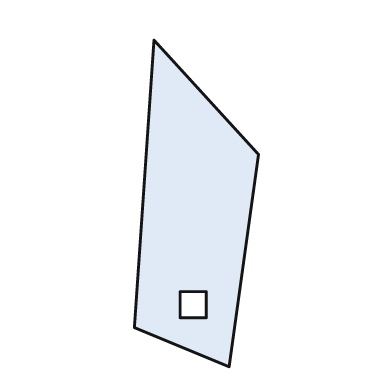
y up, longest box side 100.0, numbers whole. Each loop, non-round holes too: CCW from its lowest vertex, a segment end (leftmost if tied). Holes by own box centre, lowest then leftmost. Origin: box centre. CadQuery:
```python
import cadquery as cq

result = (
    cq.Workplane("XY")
    .moveTo(10.0, -50.0)
    .lineTo(19.0, 15.0)
    .lineTo(-13.0, 50.0)
    .lineTo(-19.0, -38.0)
    .close()
    .moveTo(-5.0, -35.0)
    .lineTo(3.0, -35.0)
    .lineTo(3.0, -27.0)
    .lineTo(-5.0, -27.0)
    .close()
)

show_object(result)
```